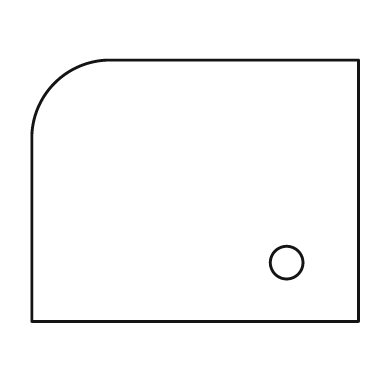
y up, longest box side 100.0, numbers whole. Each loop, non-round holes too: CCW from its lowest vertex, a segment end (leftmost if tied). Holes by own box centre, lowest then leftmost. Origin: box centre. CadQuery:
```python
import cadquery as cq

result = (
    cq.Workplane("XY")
    .moveTo(-50.0, -40.0)
    .lineTo(50.0, -40.0)
    .lineTo(50.0, 40.0)
    .lineTo(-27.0, 40.0)
    .threePointArc((-43.0, 33.0), (-50.0, 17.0))
    .close()
    .moveTo(28.0, -22.0)
    .circle(5.0)
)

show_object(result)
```